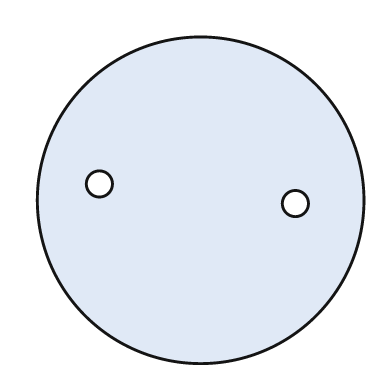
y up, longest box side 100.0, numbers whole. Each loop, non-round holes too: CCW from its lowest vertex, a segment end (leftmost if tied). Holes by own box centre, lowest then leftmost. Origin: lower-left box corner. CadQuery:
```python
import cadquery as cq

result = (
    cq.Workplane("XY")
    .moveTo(50.0, 50.0)
    .circle(50.0)
    .moveTo(79.0, 49.0)
    .circle(4.0)
    .moveTo(19.0, 55.0)
    .circle(4.0)
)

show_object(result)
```